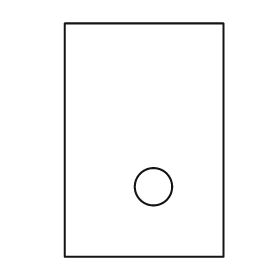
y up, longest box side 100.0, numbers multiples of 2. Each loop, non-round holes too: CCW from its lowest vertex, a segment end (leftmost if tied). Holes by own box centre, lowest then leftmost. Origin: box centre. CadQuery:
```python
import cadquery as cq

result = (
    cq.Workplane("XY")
    .moveTo(-34.0, -50.0)
    .lineTo(34.0, -50.0)
    .lineTo(34.0, 50.0)
    .lineTo(-34.0, 50.0)
    .close()
    .moveTo(4.0, -20.0)
    .circle(8.0)
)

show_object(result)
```